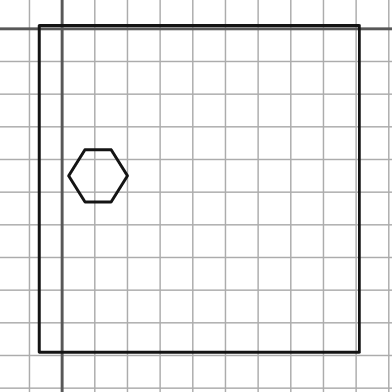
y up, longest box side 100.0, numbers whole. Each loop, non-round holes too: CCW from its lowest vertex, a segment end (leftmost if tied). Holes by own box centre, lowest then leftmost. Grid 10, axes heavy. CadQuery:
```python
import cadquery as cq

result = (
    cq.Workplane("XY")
    .moveTo(-7.0, -99.0)
    .lineTo(91.0, -99.0)
    .lineTo(91.0, 1.0)
    .lineTo(-7.0, 1.0)
    .close()
    .moveTo(7.0, -53.0)
    .lineTo(15.0, -53.0)
    .lineTo(20.0, -45.0)
    .lineTo(15.0, -37.0)
    .lineTo(7.0, -37.0)
    .lineTo(2.0, -45.0)
    .close()
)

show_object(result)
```